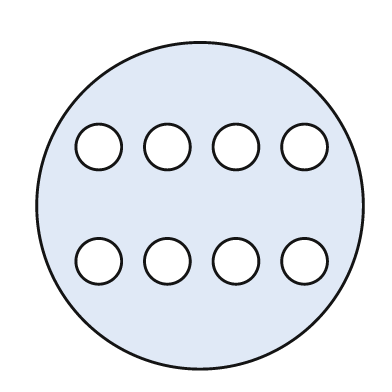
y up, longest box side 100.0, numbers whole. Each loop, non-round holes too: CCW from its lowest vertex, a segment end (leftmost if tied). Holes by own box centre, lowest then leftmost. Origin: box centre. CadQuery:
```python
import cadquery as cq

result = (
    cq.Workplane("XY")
    .moveTo(0.0, 0.0)
    .circle(50.0)
    .moveTo(-31.0, -17.0)
    .circle(7.0)
    .moveTo(-10.0, -17.0)
    .circle(7.0)
    .moveTo(11.0, -17.0)
    .circle(7.0)
    .moveTo(32.0, -17.0)
    .circle(7.0)
    .moveTo(-31.0, 18.0)
    .circle(7.0)
    .moveTo(-10.0, 18.0)
    .circle(7.0)
    .moveTo(11.0, 18.0)
    .circle(7.0)
    .moveTo(32.0, 18.0)
    .circle(7.0)
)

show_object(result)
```